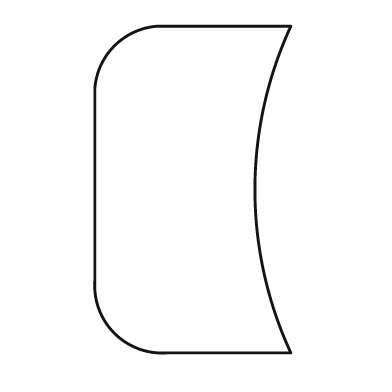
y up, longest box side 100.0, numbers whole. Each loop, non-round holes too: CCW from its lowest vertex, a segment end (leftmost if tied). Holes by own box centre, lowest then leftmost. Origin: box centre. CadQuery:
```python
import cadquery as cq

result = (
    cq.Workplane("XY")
    .moveTo(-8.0, -50.0)
    .lineTo(30.0, -50.0)
    .threePointArc((19.0, 0.0), (30.0, 50.0))
    .lineTo(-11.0, 50.0)
    .threePointArc((-24.0, 44.0), (-30.0, 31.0))
    .lineTo(-30.0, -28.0)
    .threePointArc((-24.0, -44.0), (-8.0, -50.0))
    .close()
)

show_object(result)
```